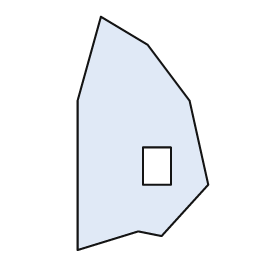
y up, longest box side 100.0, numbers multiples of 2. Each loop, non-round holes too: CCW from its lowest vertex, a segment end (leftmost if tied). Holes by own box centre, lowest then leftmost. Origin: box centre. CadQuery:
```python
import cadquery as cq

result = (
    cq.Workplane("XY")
    .moveTo(-28.0, -50.0)
    .lineTo(-2.0, -42.0)
    .lineTo(8.0, -44.0)
    .lineTo(28.0, -22.0)
    .lineTo(20.0, 14.0)
    .lineTo(2.0, 38.0)
    .lineTo(-18.0, 50.0)
    .lineTo(-28.0, 14.0)
    .close()
    .moveTo(0.0, -22.0)
    .lineTo(12.0, -22.0)
    .lineTo(12.0, -6.0)
    .lineTo(0.0, -6.0)
    .close()
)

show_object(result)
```